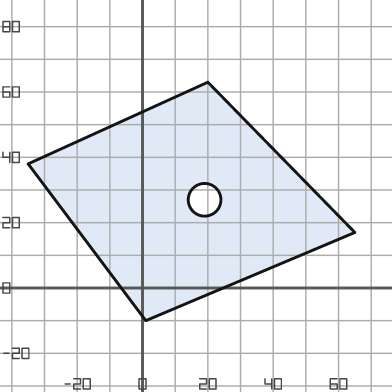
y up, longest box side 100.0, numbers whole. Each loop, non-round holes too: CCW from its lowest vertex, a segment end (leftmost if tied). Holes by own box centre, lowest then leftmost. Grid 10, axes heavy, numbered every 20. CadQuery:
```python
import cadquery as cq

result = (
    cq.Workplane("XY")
    .moveTo(1.0, -10.0)
    .lineTo(65.0, 17.0)
    .lineTo(20.0, 63.0)
    .lineTo(-35.0, 38.0)
    .close()
    .moveTo(19.0, 27.0)
    .circle(5.0)
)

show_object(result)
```